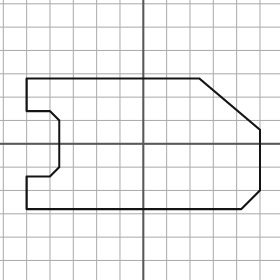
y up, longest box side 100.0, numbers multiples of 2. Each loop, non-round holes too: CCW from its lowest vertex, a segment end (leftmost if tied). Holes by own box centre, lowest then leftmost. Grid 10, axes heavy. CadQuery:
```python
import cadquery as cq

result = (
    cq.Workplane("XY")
    .moveTo(-50.0, -28.0)
    .lineTo(42.0, -28.0)
    .lineTo(50.0, -20.0)
    .lineTo(50.0, 6.0)
    .lineTo(24.0, 28.0)
    .lineTo(-50.0, 28.0)
    .lineTo(-50.0, 14.0)
    .lineTo(-40.0, 14.0)
    .lineTo(-36.0, 10.0)
    .lineTo(-36.0, -10.0)
    .lineTo(-40.0, -14.0)
    .lineTo(-50.0, -14.0)
    .close()
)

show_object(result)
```